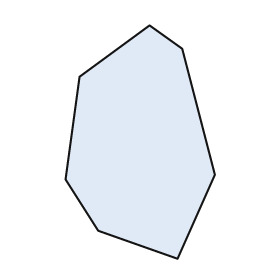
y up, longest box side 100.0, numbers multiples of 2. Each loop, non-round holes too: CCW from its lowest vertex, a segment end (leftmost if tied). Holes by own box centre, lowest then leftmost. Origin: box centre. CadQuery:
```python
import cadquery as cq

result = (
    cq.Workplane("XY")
    .moveTo(16.0, -50.0)
    .lineTo(32.0, -14.0)
    .lineTo(18.0, 40.0)
    .lineTo(4.0, 50.0)
    .lineTo(-26.0, 28.0)
    .lineTo(-32.0, -16.0)
    .lineTo(-18.0, -38.0)
    .close()
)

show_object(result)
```